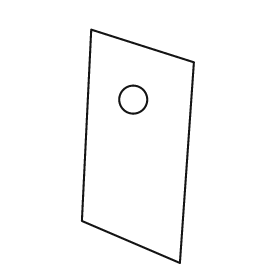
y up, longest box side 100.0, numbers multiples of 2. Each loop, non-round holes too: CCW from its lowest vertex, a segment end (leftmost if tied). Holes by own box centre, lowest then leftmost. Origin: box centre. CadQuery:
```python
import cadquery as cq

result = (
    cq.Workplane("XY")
    .moveTo(18.0, -50.0)
    .lineTo(24.0, 36.0)
    .lineTo(-20.0, 50.0)
    .lineTo(-24.0, -32.0)
    .close()
    .moveTo(-2.0, 20.0)
    .circle(6.0)
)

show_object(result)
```